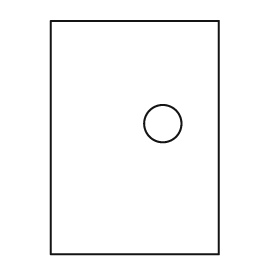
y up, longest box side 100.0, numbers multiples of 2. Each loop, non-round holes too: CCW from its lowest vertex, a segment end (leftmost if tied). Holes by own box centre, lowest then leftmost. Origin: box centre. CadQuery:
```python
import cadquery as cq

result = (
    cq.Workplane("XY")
    .moveTo(-36.0, -50.0)
    .lineTo(36.0, -50.0)
    .lineTo(36.0, 50.0)
    .lineTo(-36.0, 50.0)
    .close()
    .moveTo(12.0, 6.0)
    .circle(8.0)
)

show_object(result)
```